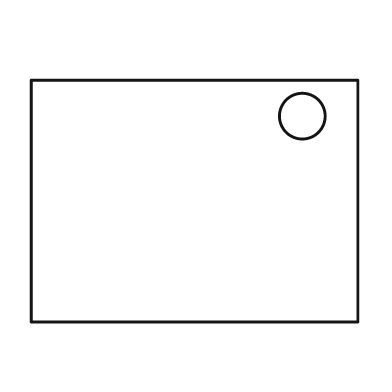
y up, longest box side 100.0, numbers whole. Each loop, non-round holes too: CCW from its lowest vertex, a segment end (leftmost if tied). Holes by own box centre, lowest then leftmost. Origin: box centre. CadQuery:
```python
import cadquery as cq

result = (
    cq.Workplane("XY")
    .moveTo(-50.0, -37.0)
    .lineTo(50.0, -37.0)
    .lineTo(50.0, 37.0)
    .lineTo(-50.0, 37.0)
    .close()
    .moveTo(33.0, 26.0)
    .circle(7.0)
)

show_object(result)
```